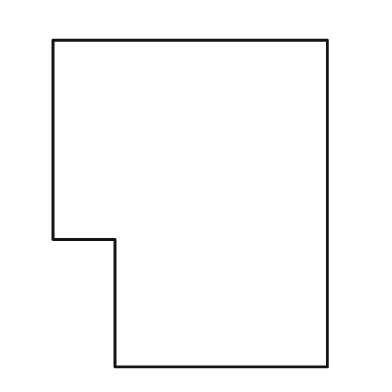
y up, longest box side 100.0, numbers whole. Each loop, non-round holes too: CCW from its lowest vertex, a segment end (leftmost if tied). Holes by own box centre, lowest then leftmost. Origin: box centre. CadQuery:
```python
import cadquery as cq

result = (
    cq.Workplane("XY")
    .moveTo(-23.0, -50.0)
    .lineTo(42.0, -50.0)
    .lineTo(42.0, 50.0)
    .lineTo(-42.0, 50.0)
    .lineTo(-42.0, -11.0)
    .lineTo(-23.0, -11.0)
    .close()
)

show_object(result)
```